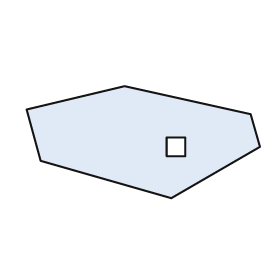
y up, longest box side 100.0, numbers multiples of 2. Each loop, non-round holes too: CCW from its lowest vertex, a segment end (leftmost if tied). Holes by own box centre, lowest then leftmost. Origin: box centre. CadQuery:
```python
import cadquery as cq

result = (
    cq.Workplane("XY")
    .moveTo(12.0, -24.0)
    .lineTo(50.0, -2.0)
    .lineTo(46.0, 12.0)
    .lineTo(-8.0, 24.0)
    .lineTo(-50.0, 14.0)
    .lineTo(-44.0, -8.0)
    .close()
    .moveTo(10.0, -6.0)
    .lineTo(18.0, -6.0)
    .lineTo(18.0, 2.0)
    .lineTo(10.0, 2.0)
    .close()
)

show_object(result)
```